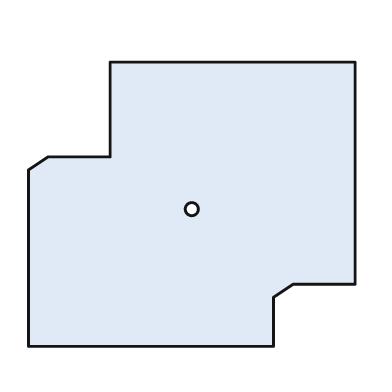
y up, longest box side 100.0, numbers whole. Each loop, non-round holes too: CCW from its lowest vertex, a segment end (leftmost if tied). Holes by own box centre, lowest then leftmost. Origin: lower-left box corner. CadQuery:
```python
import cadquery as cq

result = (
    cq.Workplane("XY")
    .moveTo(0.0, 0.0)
    .lineTo(75.0, 0.0)
    .lineTo(75.0, 15.0)
    .lineTo(81.0, 19.0)
    .lineTo(100.0, 19.0)
    .lineTo(100.0, 87.0)
    .lineTo(25.0, 87.0)
    .lineTo(25.0, 58.0)
    .lineTo(6.0, 58.0)
    .lineTo(0.0, 54.0)
    .close()
    .moveTo(50.0, 42.0)
    .circle(2.0)
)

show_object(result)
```